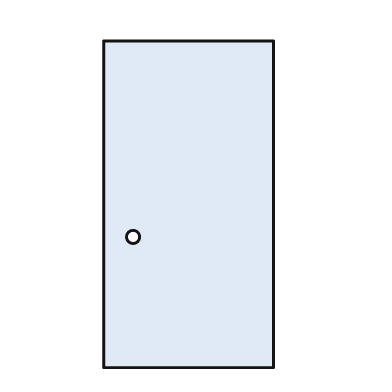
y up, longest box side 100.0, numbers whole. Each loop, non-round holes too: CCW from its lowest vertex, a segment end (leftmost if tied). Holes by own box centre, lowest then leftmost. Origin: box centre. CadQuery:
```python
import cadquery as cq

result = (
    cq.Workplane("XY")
    .moveTo(-26.0, -50.0)
    .lineTo(26.0, -50.0)
    .lineTo(26.0, 50.0)
    .lineTo(-26.0, 50.0)
    .close()
    .moveTo(-17.0, -10.0)
    .circle(2.0)
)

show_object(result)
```